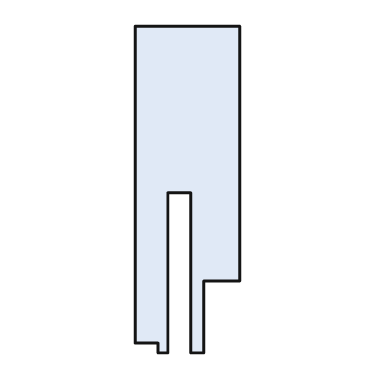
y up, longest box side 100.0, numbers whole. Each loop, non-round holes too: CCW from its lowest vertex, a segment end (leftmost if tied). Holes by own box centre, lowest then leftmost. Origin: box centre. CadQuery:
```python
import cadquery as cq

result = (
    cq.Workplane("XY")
    .moveTo(-9.0, -50.0)
    .lineTo(-6.0, -50.0)
    .lineTo(-6.0, -1.0)
    .lineTo(1.0, -1.0)
    .lineTo(1.0, -50.0)
    .lineTo(5.0, -50.0)
    .lineTo(5.0, -28.0)
    .lineTo(16.0, -28.0)
    .lineTo(16.0, 50.0)
    .lineTo(-16.0, 50.0)
    .lineTo(-16.0, -47.0)
    .lineTo(-9.0, -47.0)
    .close()
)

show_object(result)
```